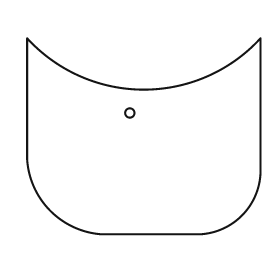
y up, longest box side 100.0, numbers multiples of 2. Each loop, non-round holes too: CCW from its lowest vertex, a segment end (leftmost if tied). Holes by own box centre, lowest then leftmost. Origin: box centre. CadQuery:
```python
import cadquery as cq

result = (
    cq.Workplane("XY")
    .moveTo(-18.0, -42.0)
    .lineTo(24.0, -42.0)
    .threePointArc((42.0, -34.0), (50.0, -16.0))
    .lineTo(50.0, 42.0)
    .threePointArc((0.0, 20.0), (-50.0, 42.0))
    .lineTo(-50.0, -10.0)
    .threePointArc((-40.0, -32.0), (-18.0, -42.0))
    .close()
    .moveTo(-6.0, 10.0)
    .circle(2.0)
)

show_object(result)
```